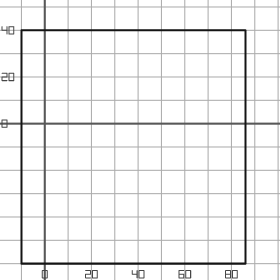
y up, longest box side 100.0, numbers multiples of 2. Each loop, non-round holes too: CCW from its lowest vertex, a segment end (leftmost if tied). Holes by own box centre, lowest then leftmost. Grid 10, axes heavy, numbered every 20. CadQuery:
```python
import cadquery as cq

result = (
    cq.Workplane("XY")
    .moveTo(-10.0, -60.0)
    .lineTo(86.0, -60.0)
    .lineTo(86.0, 40.0)
    .lineTo(-10.0, 40.0)
    .close()
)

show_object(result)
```